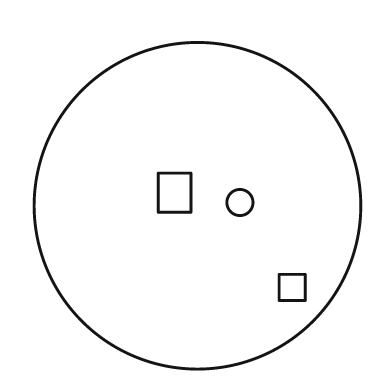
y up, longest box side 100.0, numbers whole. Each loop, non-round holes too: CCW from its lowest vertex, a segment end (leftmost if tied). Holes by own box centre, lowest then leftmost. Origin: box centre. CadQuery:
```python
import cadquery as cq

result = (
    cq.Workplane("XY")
    .moveTo(0.0, 0.0)
    .circle(50.0)
    .moveTo(25.0, -29.0)
    .lineTo(33.0, -29.0)
    .lineTo(33.0, -21.0)
    .lineTo(25.0, -21.0)
    .close()
    .moveTo(13.0, 1.0)
    .circle(4.0)
    .moveTo(-12.0, -2.0)
    .lineTo(-2.0, -2.0)
    .lineTo(-2.0, 10.0)
    .lineTo(-12.0, 10.0)
    .close()
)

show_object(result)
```